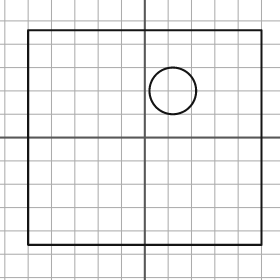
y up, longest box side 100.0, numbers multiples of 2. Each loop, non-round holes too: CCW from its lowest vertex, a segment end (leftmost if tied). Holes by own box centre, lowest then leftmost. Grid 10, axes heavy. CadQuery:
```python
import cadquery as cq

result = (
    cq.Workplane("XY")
    .moveTo(-50.0, -46.0)
    .lineTo(50.0, -46.0)
    .lineTo(50.0, 46.0)
    .lineTo(-50.0, 46.0)
    .close()
    .moveTo(12.0, 20.0)
    .circle(10.0)
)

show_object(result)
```